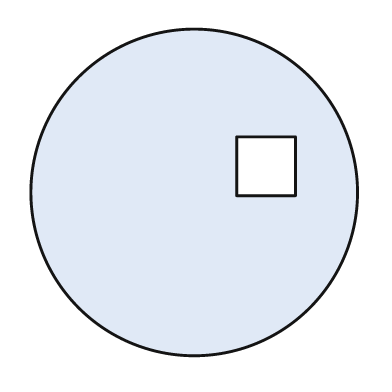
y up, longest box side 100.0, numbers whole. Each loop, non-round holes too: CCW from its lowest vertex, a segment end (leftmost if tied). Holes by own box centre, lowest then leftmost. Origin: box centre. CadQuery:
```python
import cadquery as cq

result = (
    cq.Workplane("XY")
    .moveTo(0.0, 0.0)
    .circle(50.0)
    .moveTo(13.0, -1.0)
    .lineTo(31.0, -1.0)
    .lineTo(31.0, 17.0)
    .lineTo(13.0, 17.0)
    .close()
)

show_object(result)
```